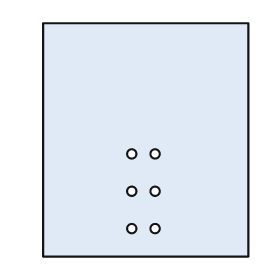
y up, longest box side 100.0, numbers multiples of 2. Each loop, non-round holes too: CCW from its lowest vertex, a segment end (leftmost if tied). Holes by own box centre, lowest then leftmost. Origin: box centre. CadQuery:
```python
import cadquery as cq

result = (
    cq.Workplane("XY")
    .moveTo(-44.0, -50.0)
    .lineTo(44.0, -50.0)
    .lineTo(44.0, 50.0)
    .lineTo(-44.0, 50.0)
    .close()
    .moveTo(-6.0, -38.0)
    .circle(2.0)
    .moveTo(4.0, -38.0)
    .circle(2.0)
    .moveTo(-6.0, -22.0)
    .circle(2.0)
    .moveTo(4.0, -22.0)
    .circle(2.0)
    .moveTo(-6.0, -6.0)
    .circle(2.0)
    .moveTo(4.0, -6.0)
    .circle(2.0)
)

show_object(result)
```